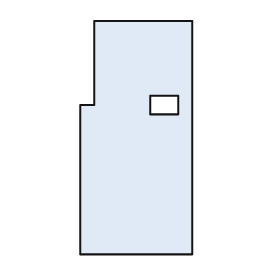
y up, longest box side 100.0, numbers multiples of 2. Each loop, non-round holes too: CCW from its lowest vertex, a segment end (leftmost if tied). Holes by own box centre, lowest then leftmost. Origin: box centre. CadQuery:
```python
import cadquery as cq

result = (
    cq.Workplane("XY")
    .moveTo(-24.0, -50.0)
    .lineTo(24.0, -50.0)
    .lineTo(24.0, 50.0)
    .lineTo(-18.0, 50.0)
    .lineTo(-18.0, 14.0)
    .lineTo(-24.0, 14.0)
    .close()
    .moveTo(6.0, 10.0)
    .lineTo(18.0, 10.0)
    .lineTo(18.0, 18.0)
    .lineTo(6.0, 18.0)
    .close()
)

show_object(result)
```